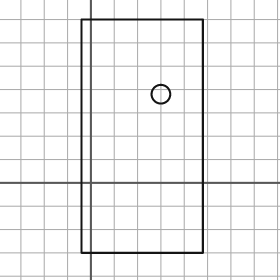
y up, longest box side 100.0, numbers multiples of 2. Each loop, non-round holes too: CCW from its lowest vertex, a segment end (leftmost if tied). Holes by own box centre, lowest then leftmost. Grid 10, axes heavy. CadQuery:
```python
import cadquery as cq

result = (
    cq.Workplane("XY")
    .moveTo(-4.0, -30.0)
    .lineTo(48.0, -30.0)
    .lineTo(48.0, 70.0)
    .lineTo(-4.0, 70.0)
    .close()
    .moveTo(30.0, 38.0)
    .circle(4.0)
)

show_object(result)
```